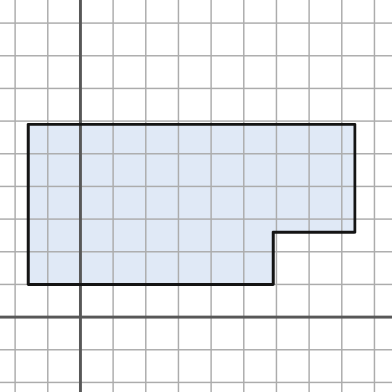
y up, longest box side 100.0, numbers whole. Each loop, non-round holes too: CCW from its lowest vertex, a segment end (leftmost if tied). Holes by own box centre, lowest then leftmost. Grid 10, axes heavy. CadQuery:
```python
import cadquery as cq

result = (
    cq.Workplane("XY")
    .moveTo(-16.0, 10.0)
    .lineTo(59.0, 10.0)
    .lineTo(59.0, 26.0)
    .lineTo(84.0, 26.0)
    .lineTo(84.0, 59.0)
    .lineTo(-16.0, 59.0)
    .close()
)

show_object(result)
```